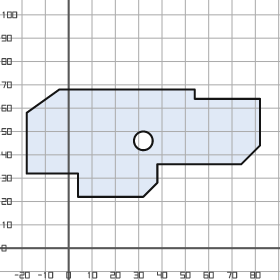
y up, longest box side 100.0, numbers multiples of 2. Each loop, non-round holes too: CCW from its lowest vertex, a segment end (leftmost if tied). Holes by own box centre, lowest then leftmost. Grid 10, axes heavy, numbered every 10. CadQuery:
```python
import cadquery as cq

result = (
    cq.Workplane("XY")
    .moveTo(4.0, 22.0)
    .lineTo(32.0, 22.0)
    .lineTo(38.0, 28.0)
    .lineTo(38.0, 36.0)
    .lineTo(74.0, 36.0)
    .lineTo(82.0, 44.0)
    .lineTo(82.0, 64.0)
    .lineTo(54.0, 64.0)
    .lineTo(54.0, 68.0)
    .lineTo(-4.0, 68.0)
    .lineTo(-18.0, 58.0)
    .lineTo(-18.0, 32.0)
    .lineTo(4.0, 32.0)
    .close()
    .moveTo(32.0, 46.0)
    .circle(4.0)
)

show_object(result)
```